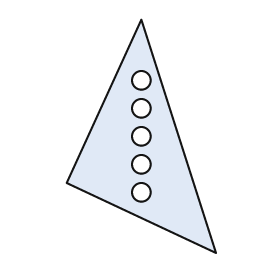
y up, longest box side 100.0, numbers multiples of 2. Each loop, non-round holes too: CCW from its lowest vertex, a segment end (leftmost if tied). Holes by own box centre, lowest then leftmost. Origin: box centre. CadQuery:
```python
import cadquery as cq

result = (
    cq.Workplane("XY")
    .moveTo(32.0, -50.0)
    .lineTo(0.0, 50.0)
    .lineTo(-32.0, -20.0)
    .close()
    .moveTo(0.0, -24.0)
    .circle(4.0)
    .moveTo(0.0, -12.0)
    .circle(4.0)
    .moveTo(0.0, 0.0)
    .circle(4.0)
    .moveTo(0.0, 12.0)
    .circle(4.0)
    .moveTo(0.0, 24.0)
    .circle(4.0)
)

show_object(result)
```